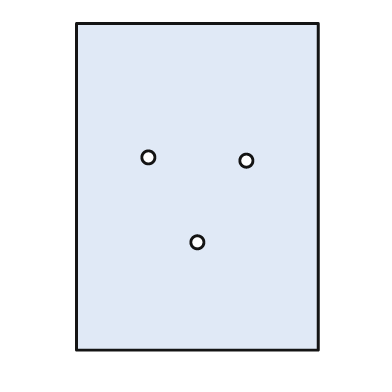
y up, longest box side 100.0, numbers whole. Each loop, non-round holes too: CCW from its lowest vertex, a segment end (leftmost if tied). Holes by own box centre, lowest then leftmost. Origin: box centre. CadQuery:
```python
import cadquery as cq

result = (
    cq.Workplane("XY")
    .moveTo(-37.0, -50.0)
    .lineTo(37.0, -50.0)
    .lineTo(37.0, 50.0)
    .lineTo(-37.0, 50.0)
    .close()
    .moveTo(0.0, -17.0)
    .circle(2.0)
    .moveTo(15.0, 8.0)
    .circle(2.0)
    .moveTo(-15.0, 9.0)
    .circle(2.0)
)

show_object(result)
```